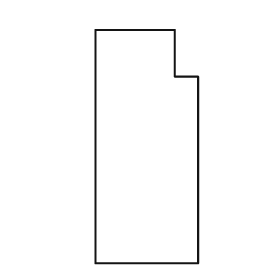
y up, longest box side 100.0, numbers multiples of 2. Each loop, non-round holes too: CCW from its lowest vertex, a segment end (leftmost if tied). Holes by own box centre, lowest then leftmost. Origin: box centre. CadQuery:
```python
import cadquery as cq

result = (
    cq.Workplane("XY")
    .moveTo(-22.0, -50.0)
    .lineTo(22.0, -50.0)
    .lineTo(22.0, 30.0)
    .lineTo(12.0, 30.0)
    .lineTo(12.0, 50.0)
    .lineTo(-22.0, 50.0)
    .close()
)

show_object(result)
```